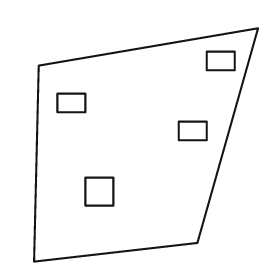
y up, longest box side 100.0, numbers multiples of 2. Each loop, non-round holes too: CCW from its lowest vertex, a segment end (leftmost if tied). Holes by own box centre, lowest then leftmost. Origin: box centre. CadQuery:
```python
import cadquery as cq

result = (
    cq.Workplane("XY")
    .moveTo(-48.0, -50.0)
    .lineTo(22.0, -42.0)
    .lineTo(48.0, 50.0)
    .lineTo(-46.0, 34.0)
    .close()
    .moveTo(-26.0, -26.0)
    .lineTo(-14.0, -26.0)
    .lineTo(-14.0, -14.0)
    .lineTo(-26.0, -14.0)
    .close()
    .moveTo(14.0, 2.0)
    .lineTo(26.0, 2.0)
    .lineTo(26.0, 10.0)
    .lineTo(14.0, 10.0)
    .close()
    .moveTo(-38.0, 14.0)
    .lineTo(-26.0, 14.0)
    .lineTo(-26.0, 22.0)
    .lineTo(-38.0, 22.0)
    .close()
    .moveTo(26.0, 32.0)
    .lineTo(38.0, 32.0)
    .lineTo(38.0, 40.0)
    .lineTo(26.0, 40.0)
    .close()
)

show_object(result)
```